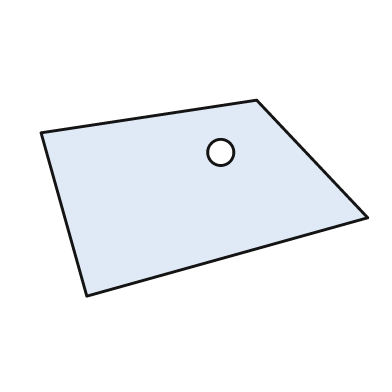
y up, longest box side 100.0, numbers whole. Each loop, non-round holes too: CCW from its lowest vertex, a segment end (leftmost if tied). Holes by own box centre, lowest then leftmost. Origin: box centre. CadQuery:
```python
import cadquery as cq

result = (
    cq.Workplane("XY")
    .moveTo(-36.0, -30.0)
    .lineTo(50.0, -6.0)
    .lineTo(16.0, 30.0)
    .lineTo(-50.0, 20.0)
    .close()
    .moveTo(5.0, 14.0)
    .circle(4.0)
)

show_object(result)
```